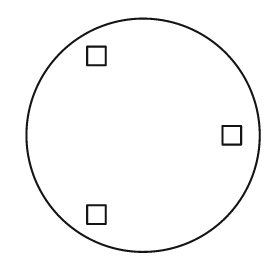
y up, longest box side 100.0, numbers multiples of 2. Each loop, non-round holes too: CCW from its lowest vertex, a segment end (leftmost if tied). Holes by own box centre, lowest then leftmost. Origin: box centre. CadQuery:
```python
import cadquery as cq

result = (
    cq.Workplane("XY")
    .moveTo(0.0, 0.0)
    .circle(50.0)
    .moveTo(-24.0, -38.0)
    .lineTo(-16.0, -38.0)
    .lineTo(-16.0, -30.0)
    .lineTo(-24.0, -30.0)
    .close()
    .moveTo(34.0, -4.0)
    .lineTo(42.0, -4.0)
    .lineTo(42.0, 4.0)
    .lineTo(34.0, 4.0)
    .close()
    .moveTo(-24.0, 30.0)
    .lineTo(-16.0, 30.0)
    .lineTo(-16.0, 38.0)
    .lineTo(-24.0, 38.0)
    .close()
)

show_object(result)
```